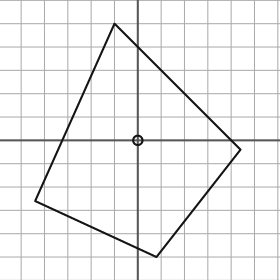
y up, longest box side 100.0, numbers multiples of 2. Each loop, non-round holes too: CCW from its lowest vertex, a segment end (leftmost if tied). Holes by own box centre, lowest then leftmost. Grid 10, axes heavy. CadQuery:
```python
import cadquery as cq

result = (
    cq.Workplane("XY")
    .moveTo(8.0, -50.0)
    .lineTo(44.0, -4.0)
    .lineTo(-10.0, 50.0)
    .lineTo(-44.0, -26.0)
    .close()
    .moveTo(0.0, 0.0)
    .circle(2.0)
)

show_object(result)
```